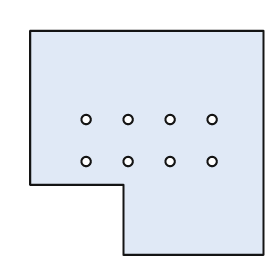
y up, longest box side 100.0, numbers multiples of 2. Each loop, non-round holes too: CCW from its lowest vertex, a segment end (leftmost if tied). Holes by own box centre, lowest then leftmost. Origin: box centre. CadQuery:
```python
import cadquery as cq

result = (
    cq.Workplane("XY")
    .moveTo(-10.0, -48.0)
    .lineTo(50.0, -48.0)
    .lineTo(50.0, 48.0)
    .lineTo(-50.0, 48.0)
    .lineTo(-50.0, -18.0)
    .lineTo(-10.0, -18.0)
    .close()
    .moveTo(-26.0, -8.0)
    .circle(2.0)
    .moveTo(-8.0, -8.0)
    .circle(2.0)
    .moveTo(10.0, -8.0)
    .circle(2.0)
    .moveTo(28.0, -8.0)
    .circle(2.0)
    .moveTo(-26.0, 10.0)
    .circle(2.0)
    .moveTo(-8.0, 10.0)
    .circle(2.0)
    .moveTo(10.0, 10.0)
    .circle(2.0)
    .moveTo(28.0, 10.0)
    .circle(2.0)
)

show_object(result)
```